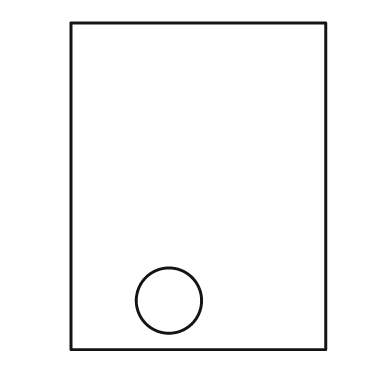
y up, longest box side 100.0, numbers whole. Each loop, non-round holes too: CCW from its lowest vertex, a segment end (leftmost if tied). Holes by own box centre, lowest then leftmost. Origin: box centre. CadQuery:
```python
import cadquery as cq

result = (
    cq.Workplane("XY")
    .moveTo(-39.0, -50.0)
    .lineTo(39.0, -50.0)
    .lineTo(39.0, 50.0)
    .lineTo(-39.0, 50.0)
    .close()
    .moveTo(-9.0, -35.0)
    .circle(10.0)
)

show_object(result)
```